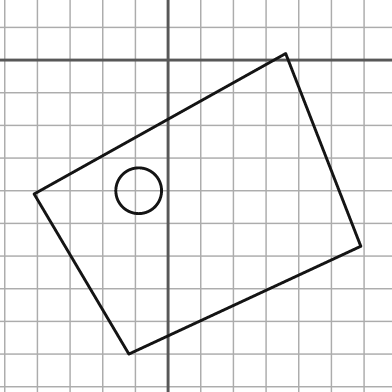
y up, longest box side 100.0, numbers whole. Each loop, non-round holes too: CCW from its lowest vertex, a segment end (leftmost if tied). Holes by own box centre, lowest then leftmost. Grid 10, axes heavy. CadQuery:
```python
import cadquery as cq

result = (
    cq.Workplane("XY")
    .moveTo(-12.0, -90.0)
    .lineTo(59.0, -57.0)
    .lineTo(36.0, 2.0)
    .lineTo(-41.0, -41.0)
    .close()
    .moveTo(-9.0, -40.0)
    .circle(7.0)
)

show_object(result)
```